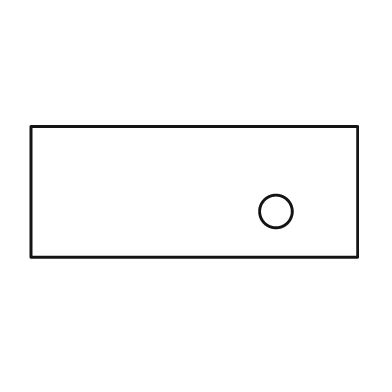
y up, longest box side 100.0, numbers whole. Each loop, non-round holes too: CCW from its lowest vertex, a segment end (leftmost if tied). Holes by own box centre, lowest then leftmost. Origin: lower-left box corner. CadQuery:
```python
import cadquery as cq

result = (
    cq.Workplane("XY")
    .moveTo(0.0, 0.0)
    .lineTo(100.0, 0.0)
    .lineTo(100.0, 40.0)
    .lineTo(0.0, 40.0)
    .close()
    .moveTo(75.0, 14.0)
    .circle(5.0)
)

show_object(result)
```